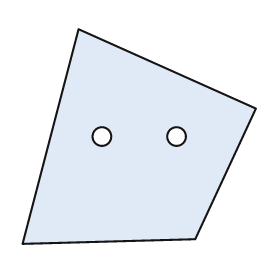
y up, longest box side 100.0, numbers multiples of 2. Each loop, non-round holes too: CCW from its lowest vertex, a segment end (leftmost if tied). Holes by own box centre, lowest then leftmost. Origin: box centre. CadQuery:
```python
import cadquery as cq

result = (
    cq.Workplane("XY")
    .moveTo(-50.0, -46.0)
    .lineTo(24.0, -44.0)
    .lineTo(50.0, 12.0)
    .lineTo(-26.0, 46.0)
    .close()
    .moveTo(-16.0, 0.0)
    .circle(4.0)
    .moveTo(16.0, 0.0)
    .circle(4.0)
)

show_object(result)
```